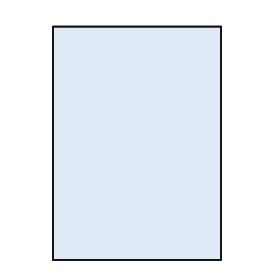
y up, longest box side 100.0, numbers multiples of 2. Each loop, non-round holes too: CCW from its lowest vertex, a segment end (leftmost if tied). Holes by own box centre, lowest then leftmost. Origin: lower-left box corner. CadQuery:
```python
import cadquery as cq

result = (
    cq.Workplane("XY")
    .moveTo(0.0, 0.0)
    .lineTo(72.0, 0.0)
    .lineTo(72.0, 100.0)
    .lineTo(0.0, 100.0)
    .close()
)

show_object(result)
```